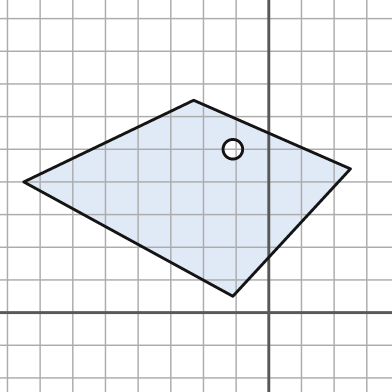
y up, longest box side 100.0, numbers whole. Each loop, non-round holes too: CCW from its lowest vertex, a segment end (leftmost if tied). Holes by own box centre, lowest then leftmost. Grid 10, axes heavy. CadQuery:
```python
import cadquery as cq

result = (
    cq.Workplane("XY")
    .moveTo(-11.0, 5.0)
    .lineTo(25.0, 44.0)
    .lineTo(-23.0, 65.0)
    .lineTo(-75.0, 40.0)
    .close()
    .moveTo(-11.0, 50.0)
    .circle(3.0)
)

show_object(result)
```